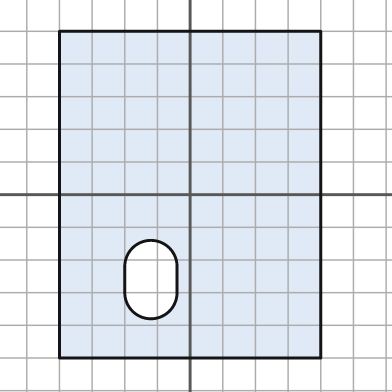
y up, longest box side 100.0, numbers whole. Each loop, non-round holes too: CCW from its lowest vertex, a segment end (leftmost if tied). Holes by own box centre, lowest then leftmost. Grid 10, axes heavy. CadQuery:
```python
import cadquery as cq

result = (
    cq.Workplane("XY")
    .moveTo(-40.0, -50.0)
    .lineTo(40.0, -50.0)
    .lineTo(40.0, 50.0)
    .lineTo(-40.0, 50.0)
    .close()
    .moveTo(-20.0, -30.0)
    .threePointArc((-12.0, -38.0), (-4.0, -30.0))
    .lineTo(-4.0, -22.0)
    .threePointArc((-12.0, -14.0), (-20.0, -22.0))
    .close()
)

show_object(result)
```